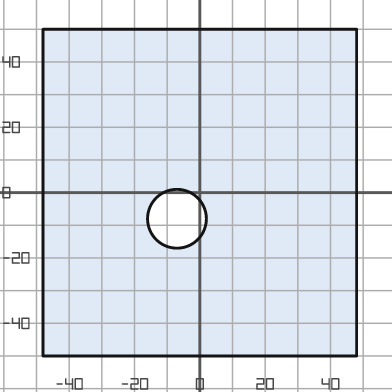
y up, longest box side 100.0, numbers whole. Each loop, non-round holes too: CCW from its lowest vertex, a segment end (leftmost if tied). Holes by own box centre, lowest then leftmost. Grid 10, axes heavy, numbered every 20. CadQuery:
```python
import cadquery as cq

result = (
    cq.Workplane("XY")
    .moveTo(-48.0, -50.0)
    .lineTo(48.0, -50.0)
    .lineTo(48.0, 50.0)
    .lineTo(-48.0, 50.0)
    .close()
    .moveTo(-7.0, -8.0)
    .circle(9.0)
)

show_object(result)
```